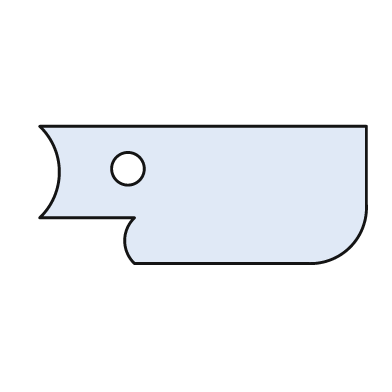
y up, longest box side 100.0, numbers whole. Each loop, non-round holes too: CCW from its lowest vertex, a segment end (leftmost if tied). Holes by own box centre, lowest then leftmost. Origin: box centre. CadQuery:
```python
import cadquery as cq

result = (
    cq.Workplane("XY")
    .moveTo(-21.0, -21.0)
    .lineTo(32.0, -21.0)
    .threePointArc((45.0, -16.0), (50.0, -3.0))
    .lineTo(50.0, 21.0)
    .lineTo(-50.0, 21.0)
    .threePointArc((-44.0, 7.0), (-50.0, -7.0))
    .lineTo(-21.0, -7.0)
    .threePointArc((-24.0, -14.0), (-21.0, -21.0))
    .close()
    .moveTo(-23.0, 8.0)
    .circle(5.0)
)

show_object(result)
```